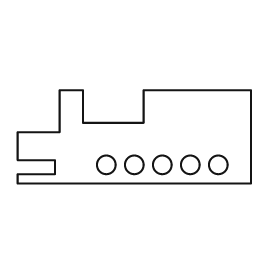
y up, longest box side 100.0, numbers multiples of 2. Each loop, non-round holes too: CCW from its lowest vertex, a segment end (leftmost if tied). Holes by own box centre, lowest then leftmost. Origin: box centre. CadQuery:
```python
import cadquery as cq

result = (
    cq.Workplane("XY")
    .moveTo(-50.0, -20.0)
    .lineTo(50.0, -20.0)
    .lineTo(50.0, 20.0)
    .lineTo(4.0, 20.0)
    .lineTo(4.0, 6.0)
    .lineTo(-22.0, 6.0)
    .lineTo(-22.0, 20.0)
    .lineTo(-32.0, 20.0)
    .lineTo(-32.0, 2.0)
    .lineTo(-50.0, 2.0)
    .lineTo(-50.0, -10.0)
    .lineTo(-34.0, -10.0)
    .lineTo(-34.0, -16.0)
    .lineTo(-50.0, -16.0)
    .close()
    .moveTo(-12.0, -12.0)
    .circle(4.0)
    .moveTo(0.0, -12.0)
    .circle(4.0)
    .moveTo(12.0, -12.0)
    .circle(4.0)
    .moveTo(24.0, -12.0)
    .circle(4.0)
    .moveTo(36.0, -12.0)
    .circle(4.0)
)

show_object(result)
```